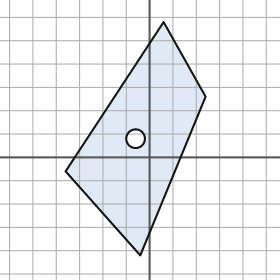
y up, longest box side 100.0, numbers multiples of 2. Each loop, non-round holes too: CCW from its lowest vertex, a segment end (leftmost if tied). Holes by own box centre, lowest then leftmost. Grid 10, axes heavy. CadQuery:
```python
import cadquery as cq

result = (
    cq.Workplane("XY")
    .moveTo(-4.0, -42.0)
    .lineTo(24.0, 26.0)
    .lineTo(6.0, 58.0)
    .lineTo(-36.0, -6.0)
    .close()
    .moveTo(-6.0, 8.0)
    .circle(4.0)
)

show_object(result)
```